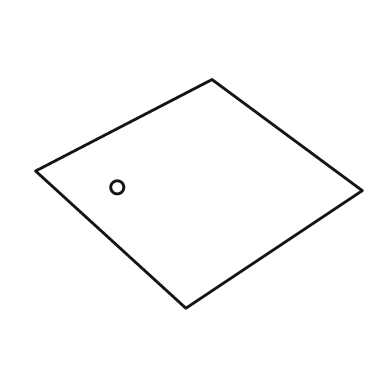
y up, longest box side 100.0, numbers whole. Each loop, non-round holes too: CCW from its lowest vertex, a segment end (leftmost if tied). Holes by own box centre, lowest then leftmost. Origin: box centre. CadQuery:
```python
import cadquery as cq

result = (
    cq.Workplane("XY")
    .moveTo(-4.0, -35.0)
    .lineTo(50.0, 1.0)
    .lineTo(4.0, 35.0)
    .lineTo(-50.0, 7.0)
    .close()
    .moveTo(-25.0, 2.0)
    .circle(2.0)
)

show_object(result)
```